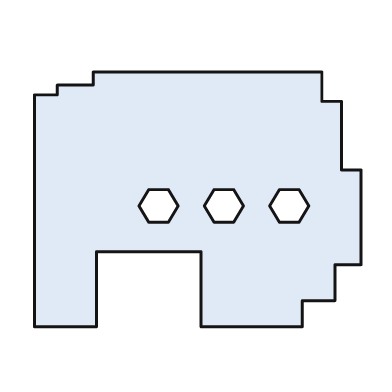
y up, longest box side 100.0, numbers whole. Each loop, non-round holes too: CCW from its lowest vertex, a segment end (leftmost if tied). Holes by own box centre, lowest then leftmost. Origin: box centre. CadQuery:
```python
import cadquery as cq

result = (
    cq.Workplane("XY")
    .moveTo(-50.0, -39.0)
    .lineTo(-31.0, -39.0)
    .lineTo(-31.0, -16.0)
    .lineTo(1.0, -16.0)
    .lineTo(1.0, -39.0)
    .lineTo(32.0, -39.0)
    .lineTo(32.0, -31.0)
    .lineTo(42.0, -31.0)
    .lineTo(42.0, -20.0)
    .lineTo(50.0, -20.0)
    .lineTo(50.0, 9.0)
    .lineTo(44.0, 9.0)
    .lineTo(44.0, 30.0)
    .lineTo(38.0, 30.0)
    .lineTo(38.0, 39.0)
    .lineTo(-32.0, 39.0)
    .lineTo(-32.0, 35.0)
    .lineTo(-43.0, 35.0)
    .lineTo(-43.0, 32.0)
    .lineTo(-50.0, 32.0)
    .close()
    .moveTo(-15.0, -7.0)
    .lineTo(-9.0, -7.0)
    .lineTo(-6.0, -2.0)
    .lineTo(-9.0, 3.0)
    .lineTo(-15.0, 3.0)
    .lineTo(-18.0, -2.0)
    .close()
    .moveTo(5.0, -7.0)
    .lineTo(11.0, -7.0)
    .lineTo(14.0, -2.0)
    .lineTo(11.0, 3.0)
    .lineTo(5.0, 3.0)
    .lineTo(2.0, -2.0)
    .close()
    .moveTo(25.0, -7.0)
    .lineTo(31.0, -7.0)
    .lineTo(34.0, -2.0)
    .lineTo(31.0, 3.0)
    .lineTo(25.0, 3.0)
    .lineTo(22.0, -2.0)
    .close()
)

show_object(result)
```